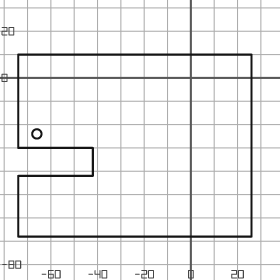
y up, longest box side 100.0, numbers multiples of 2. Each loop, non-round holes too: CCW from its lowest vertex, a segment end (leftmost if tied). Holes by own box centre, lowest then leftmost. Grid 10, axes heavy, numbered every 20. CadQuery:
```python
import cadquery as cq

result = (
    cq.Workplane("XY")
    .moveTo(-74.0, -68.0)
    .lineTo(26.0, -68.0)
    .lineTo(26.0, 10.0)
    .lineTo(-74.0, 10.0)
    .lineTo(-74.0, -30.0)
    .lineTo(-42.0, -30.0)
    .lineTo(-42.0, -42.0)
    .lineTo(-74.0, -42.0)
    .close()
    .moveTo(-66.0, -24.0)
    .circle(2.0)
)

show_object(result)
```